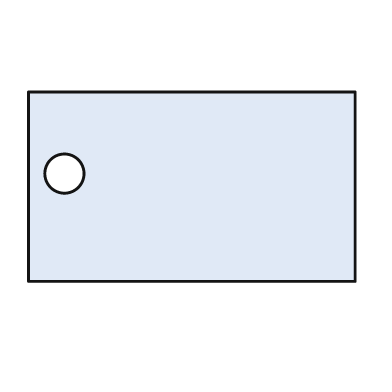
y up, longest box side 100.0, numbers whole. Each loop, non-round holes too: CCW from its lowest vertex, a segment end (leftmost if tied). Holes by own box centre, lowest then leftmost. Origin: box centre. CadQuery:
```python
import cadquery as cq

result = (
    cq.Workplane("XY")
    .moveTo(-50.0, -29.0)
    .lineTo(50.0, -29.0)
    .lineTo(50.0, 29.0)
    .lineTo(-50.0, 29.0)
    .close()
    .moveTo(-39.0, 4.0)
    .circle(6.0)
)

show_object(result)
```